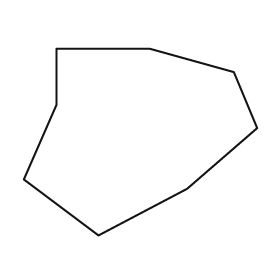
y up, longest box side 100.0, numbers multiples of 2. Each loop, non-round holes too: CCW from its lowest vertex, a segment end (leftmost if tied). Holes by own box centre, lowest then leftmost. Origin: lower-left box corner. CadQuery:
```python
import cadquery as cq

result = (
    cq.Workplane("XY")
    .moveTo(32.0, 0.0)
    .lineTo(70.0, 20.0)
    .lineTo(100.0, 46.0)
    .lineTo(90.0, 70.0)
    .lineTo(54.0, 80.0)
    .lineTo(14.0, 80.0)
    .lineTo(14.0, 56.0)
    .lineTo(0.0, 24.0)
    .close()
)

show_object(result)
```